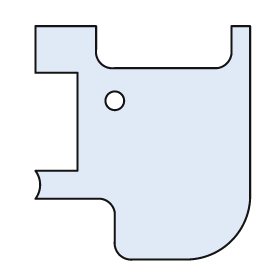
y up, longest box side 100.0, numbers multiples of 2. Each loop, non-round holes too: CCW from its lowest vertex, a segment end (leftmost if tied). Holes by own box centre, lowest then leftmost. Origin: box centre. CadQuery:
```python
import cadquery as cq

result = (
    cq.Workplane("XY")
    .moveTo(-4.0, -50.0)
    .lineTo(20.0, -50.0)
    .threePointArc((38.0, -42.0), (46.0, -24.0))
    .lineTo(46.0, 50.0)
    .lineTo(38.0, 50.0)
    .lineTo(38.0, 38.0)
    .threePointArc((36.0, 34.0), (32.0, 32.0))
    .lineTo(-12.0, 32.0)
    .threePointArc((-18.0, 34.0), (-20.0, 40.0))
    .lineTo(-20.0, 50.0)
    .lineTo(-46.0, 50.0)
    .lineTo(-46.0, 30.0)
    .lineTo(-28.0, 30.0)
    .lineTo(-28.0, -12.0)
    .lineTo(-46.0, -12.0)
    .threePointArc((-44.0, -18.0), (-46.0, -24.0))
    .lineTo(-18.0, -24.0)
    .threePointArc((-14.0, -26.0), (-12.0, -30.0))
    .lineTo(-12.0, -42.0)
    .threePointArc((-10.0, -48.0), (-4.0, -50.0))
    .close()
    .moveTo(-12.0, 18.0)
    .circle(4.0)
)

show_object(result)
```